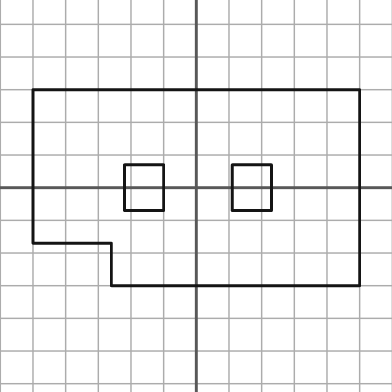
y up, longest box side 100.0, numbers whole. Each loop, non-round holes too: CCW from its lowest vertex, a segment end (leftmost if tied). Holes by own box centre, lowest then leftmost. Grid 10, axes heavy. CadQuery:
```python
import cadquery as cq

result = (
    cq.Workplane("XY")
    .moveTo(-26.0, -30.0)
    .lineTo(50.0, -30.0)
    .lineTo(50.0, 30.0)
    .lineTo(-50.0, 30.0)
    .lineTo(-50.0, -17.0)
    .lineTo(-26.0, -17.0)
    .close()
    .moveTo(-22.0, -7.0)
    .lineTo(-10.0, -7.0)
    .lineTo(-10.0, 7.0)
    .lineTo(-22.0, 7.0)
    .close()
    .moveTo(11.0, -7.0)
    .lineTo(23.0, -7.0)
    .lineTo(23.0, 7.0)
    .lineTo(11.0, 7.0)
    .close()
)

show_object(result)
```